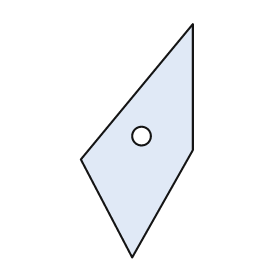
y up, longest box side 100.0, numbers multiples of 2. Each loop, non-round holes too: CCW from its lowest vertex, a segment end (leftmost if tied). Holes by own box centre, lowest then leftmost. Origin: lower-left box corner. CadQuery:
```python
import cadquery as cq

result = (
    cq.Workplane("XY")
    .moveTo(22.0, 0.0)
    .lineTo(48.0, 46.0)
    .lineTo(48.0, 100.0)
    .lineTo(0.0, 42.0)
    .close()
    .moveTo(26.0, 52.0)
    .circle(4.0)
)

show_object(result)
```